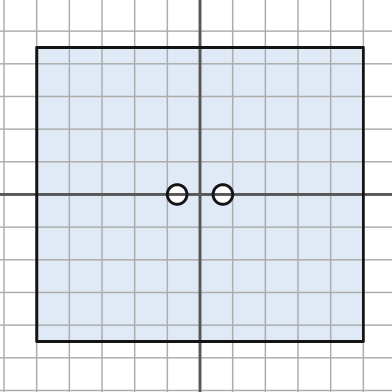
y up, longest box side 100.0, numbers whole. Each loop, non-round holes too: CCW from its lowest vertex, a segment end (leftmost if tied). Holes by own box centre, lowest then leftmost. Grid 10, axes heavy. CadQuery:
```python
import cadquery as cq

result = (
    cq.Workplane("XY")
    .moveTo(-50.0, -45.0)
    .lineTo(50.0, -45.0)
    .lineTo(50.0, 45.0)
    .lineTo(-50.0, 45.0)
    .close()
    .moveTo(-7.0, 0.0)
    .circle(3.0)
    .moveTo(7.0, 0.0)
    .circle(3.0)
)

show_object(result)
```